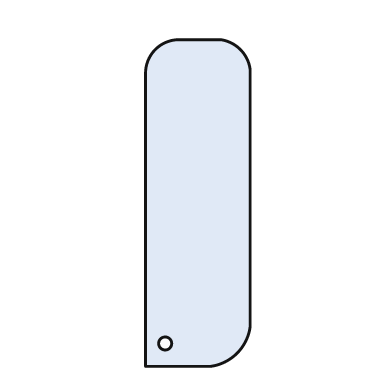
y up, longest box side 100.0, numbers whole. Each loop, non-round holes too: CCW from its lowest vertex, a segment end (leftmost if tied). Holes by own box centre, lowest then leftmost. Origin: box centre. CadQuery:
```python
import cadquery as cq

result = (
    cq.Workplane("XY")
    .moveTo(-16.0, -50.0)
    .lineTo(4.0, -50.0)
    .threePointArc((12.0, -46.0), (16.0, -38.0))
    .lineTo(16.0, 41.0)
    .threePointArc((13.0, 47.0), (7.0, 50.0))
    .lineTo(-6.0, 50.0)
    .threePointArc((-13.0, 47.0), (-16.0, 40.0))
    .close()
    .moveTo(-10.0, -43.0)
    .circle(2.0)
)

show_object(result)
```